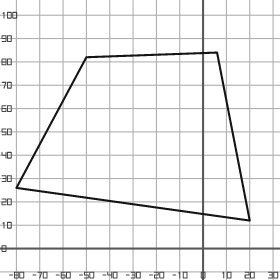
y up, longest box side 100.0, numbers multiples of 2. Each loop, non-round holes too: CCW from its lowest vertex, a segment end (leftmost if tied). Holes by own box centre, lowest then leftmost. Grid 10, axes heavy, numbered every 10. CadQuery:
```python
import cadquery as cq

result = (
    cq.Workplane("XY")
    .moveTo(20.0, 12.0)
    .lineTo(6.0, 84.0)
    .lineTo(-50.0, 82.0)
    .lineTo(-80.0, 26.0)
    .close()
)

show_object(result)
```